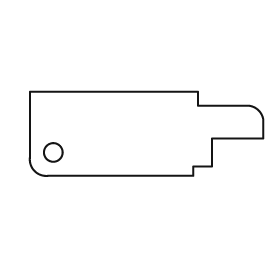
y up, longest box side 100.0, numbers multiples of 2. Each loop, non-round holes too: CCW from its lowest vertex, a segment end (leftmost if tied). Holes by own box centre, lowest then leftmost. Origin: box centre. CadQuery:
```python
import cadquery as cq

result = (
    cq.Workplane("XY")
    .moveTo(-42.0, -18.0)
    .lineTo(20.0, -18.0)
    .lineTo(20.0, -14.0)
    .lineTo(28.0, -14.0)
    .lineTo(28.0, -2.0)
    .lineTo(50.0, -2.0)
    .lineTo(50.0, 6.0)
    .threePointArc((48.0, 10.0), (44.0, 12.0))
    .lineTo(22.0, 12.0)
    .lineTo(22.0, 18.0)
    .lineTo(-50.0, 18.0)
    .lineTo(-50.0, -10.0)
    .threePointArc((-48.0, -16.0), (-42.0, -18.0))
    .close()
    .moveTo(-40.0, -8.0)
    .circle(4.0)
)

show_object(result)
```